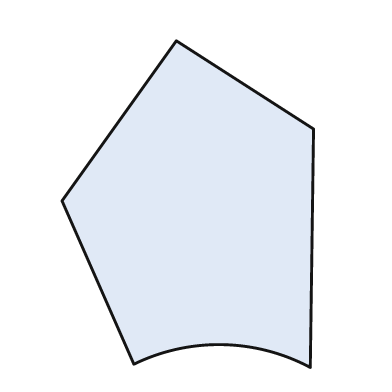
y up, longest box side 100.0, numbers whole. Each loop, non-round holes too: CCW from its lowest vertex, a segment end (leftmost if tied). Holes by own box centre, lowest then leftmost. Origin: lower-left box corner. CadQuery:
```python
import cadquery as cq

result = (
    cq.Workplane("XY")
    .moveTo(76.0, 0.0)
    .lineTo(77.0, 73.0)
    .lineTo(35.0, 100.0)
    .lineTo(0.0, 51.0)
    .lineTo(22.0, 1.0)
    .threePointArc((49.0, 7.0), (76.0, 0.0))
    .close()
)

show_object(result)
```